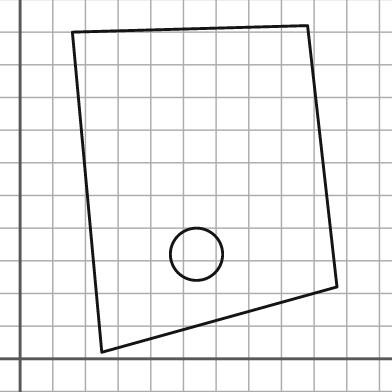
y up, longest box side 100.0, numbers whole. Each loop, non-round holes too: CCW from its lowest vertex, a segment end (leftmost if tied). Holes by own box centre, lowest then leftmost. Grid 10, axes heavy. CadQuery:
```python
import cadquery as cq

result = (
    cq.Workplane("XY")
    .moveTo(25.0, 2.0)
    .lineTo(97.0, 22.0)
    .lineTo(88.0, 102.0)
    .lineTo(16.0, 100.0)
    .close()
    .moveTo(54.0, 32.0)
    .circle(8.0)
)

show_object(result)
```